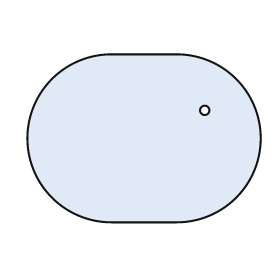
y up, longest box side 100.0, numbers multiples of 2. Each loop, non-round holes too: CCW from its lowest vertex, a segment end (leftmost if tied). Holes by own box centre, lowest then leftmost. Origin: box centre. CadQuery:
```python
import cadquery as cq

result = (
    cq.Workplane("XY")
    .moveTo(-14.0, -36.0)
    .lineTo(14.0, -36.0)
    .threePointArc((50.0, 0.0), (14.0, 36.0))
    .lineTo(-14.0, 36.0)
    .threePointArc((-50.0, 0.0), (-14.0, -36.0))
    .close()
    .moveTo(26.0, 12.0)
    .circle(2.0)
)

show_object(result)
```